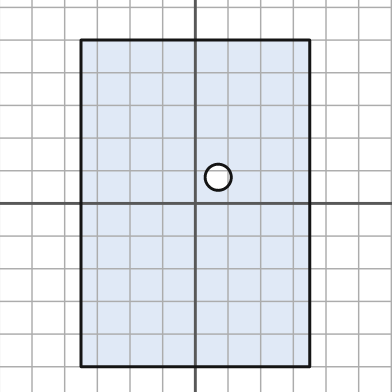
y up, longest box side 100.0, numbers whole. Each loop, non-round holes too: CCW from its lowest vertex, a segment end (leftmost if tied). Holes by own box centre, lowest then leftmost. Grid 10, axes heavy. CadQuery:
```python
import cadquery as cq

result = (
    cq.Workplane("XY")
    .moveTo(-35.0, -50.0)
    .lineTo(35.0, -50.0)
    .lineTo(35.0, 50.0)
    .lineTo(-35.0, 50.0)
    .close()
    .moveTo(7.0, 8.0)
    .circle(4.0)
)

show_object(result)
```